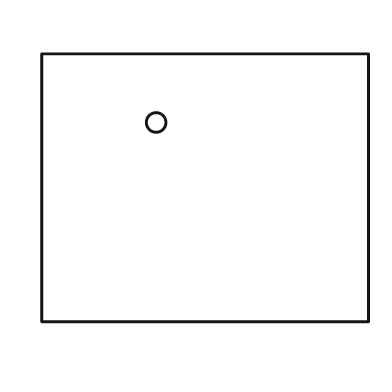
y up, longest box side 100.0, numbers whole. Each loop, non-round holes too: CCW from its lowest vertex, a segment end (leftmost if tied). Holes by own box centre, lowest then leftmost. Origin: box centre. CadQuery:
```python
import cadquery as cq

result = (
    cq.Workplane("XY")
    .moveTo(-50.0, -41.0)
    .lineTo(50.0, -41.0)
    .lineTo(50.0, 41.0)
    .lineTo(-50.0, 41.0)
    .close()
    .moveTo(-15.0, 20.0)
    .circle(3.0)
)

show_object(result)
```